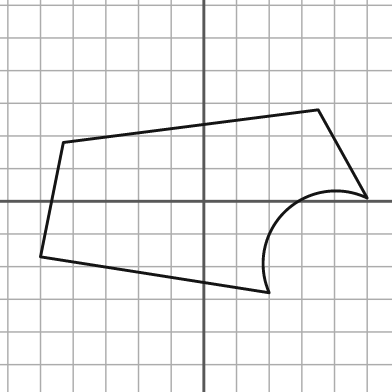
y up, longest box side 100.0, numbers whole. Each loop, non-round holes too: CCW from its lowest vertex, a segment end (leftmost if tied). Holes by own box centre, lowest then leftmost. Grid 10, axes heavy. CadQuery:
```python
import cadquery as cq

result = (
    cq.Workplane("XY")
    .moveTo(20.0, -28.0)
    .threePointArc((25.0, -3.0), (50.0, 1.0))
    .lineTo(35.0, 28.0)
    .lineTo(-43.0, 18.0)
    .lineTo(-50.0, -17.0)
    .close()
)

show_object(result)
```